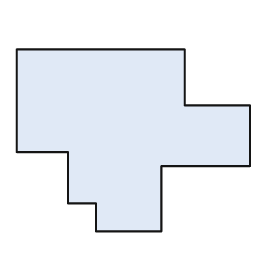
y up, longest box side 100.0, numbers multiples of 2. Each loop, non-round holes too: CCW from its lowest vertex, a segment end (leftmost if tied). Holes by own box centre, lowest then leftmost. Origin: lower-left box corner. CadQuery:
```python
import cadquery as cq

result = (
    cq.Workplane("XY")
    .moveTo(34.0, 0.0)
    .lineTo(62.0, 0.0)
    .lineTo(62.0, 28.0)
    .lineTo(100.0, 28.0)
    .lineTo(100.0, 54.0)
    .lineTo(72.0, 54.0)
    .lineTo(72.0, 78.0)
    .lineTo(0.0, 78.0)
    .lineTo(0.0, 34.0)
    .lineTo(22.0, 34.0)
    .lineTo(22.0, 12.0)
    .lineTo(34.0, 12.0)
    .close()
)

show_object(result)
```